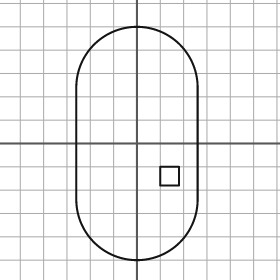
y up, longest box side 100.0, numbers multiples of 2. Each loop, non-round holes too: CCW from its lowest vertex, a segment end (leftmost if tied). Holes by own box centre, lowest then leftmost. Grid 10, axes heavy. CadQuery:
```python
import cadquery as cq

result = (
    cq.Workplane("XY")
    .moveTo(-26.0, -24.0)
    .threePointArc((0.0, -50.0), (26.0, -24.0))
    .lineTo(26.0, 24.0)
    .threePointArc((0.0, 50.0), (-26.0, 24.0))
    .close()
    .moveTo(10.0, -18.0)
    .lineTo(18.0, -18.0)
    .lineTo(18.0, -10.0)
    .lineTo(10.0, -10.0)
    .close()
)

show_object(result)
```